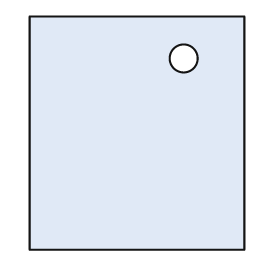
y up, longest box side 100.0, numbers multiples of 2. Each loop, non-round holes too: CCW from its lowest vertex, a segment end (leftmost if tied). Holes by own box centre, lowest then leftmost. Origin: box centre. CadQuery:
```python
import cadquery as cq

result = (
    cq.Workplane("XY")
    .moveTo(-46.0, -50.0)
    .lineTo(46.0, -50.0)
    .lineTo(46.0, 50.0)
    .lineTo(-46.0, 50.0)
    .close()
    .moveTo(20.0, 32.0)
    .circle(6.0)
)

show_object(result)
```